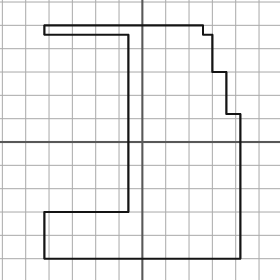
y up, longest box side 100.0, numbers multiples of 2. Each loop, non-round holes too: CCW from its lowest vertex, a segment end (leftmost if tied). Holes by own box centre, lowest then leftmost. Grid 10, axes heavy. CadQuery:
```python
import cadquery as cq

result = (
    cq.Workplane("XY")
    .moveTo(-42.0, -50.0)
    .lineTo(42.0, -50.0)
    .lineTo(42.0, 12.0)
    .lineTo(36.0, 12.0)
    .lineTo(36.0, 30.0)
    .lineTo(30.0, 30.0)
    .lineTo(30.0, 46.0)
    .lineTo(26.0, 46.0)
    .lineTo(26.0, 50.0)
    .lineTo(-42.0, 50.0)
    .lineTo(-42.0, 46.0)
    .lineTo(-6.0, 46.0)
    .lineTo(-6.0, -30.0)
    .lineTo(-42.0, -30.0)
    .close()
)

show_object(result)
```